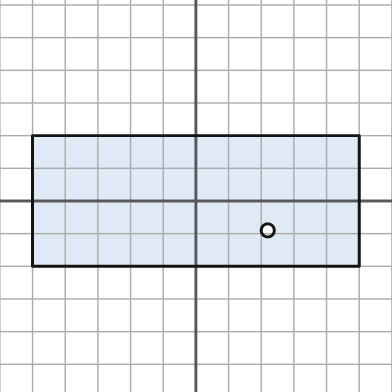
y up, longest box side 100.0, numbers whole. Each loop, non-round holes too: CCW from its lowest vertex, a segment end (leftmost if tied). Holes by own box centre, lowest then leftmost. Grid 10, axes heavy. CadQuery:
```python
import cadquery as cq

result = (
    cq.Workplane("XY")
    .moveTo(-50.0, -20.0)
    .lineTo(50.0, -20.0)
    .lineTo(50.0, 20.0)
    .lineTo(-50.0, 20.0)
    .close()
    .moveTo(22.0, -9.0)
    .circle(2.0)
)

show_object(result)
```